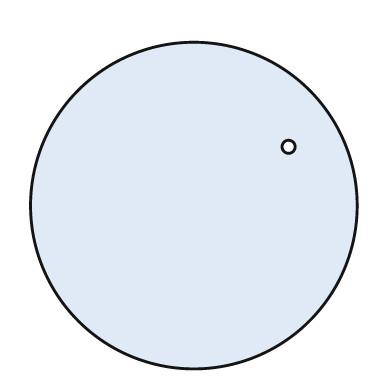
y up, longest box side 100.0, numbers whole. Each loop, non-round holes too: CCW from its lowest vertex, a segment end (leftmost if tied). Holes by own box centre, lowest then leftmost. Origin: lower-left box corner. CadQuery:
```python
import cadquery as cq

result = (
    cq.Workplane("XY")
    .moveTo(50.0, 50.0)
    .circle(50.0)
    .moveTo(79.0, 68.0)
    .circle(2.0)
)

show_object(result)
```